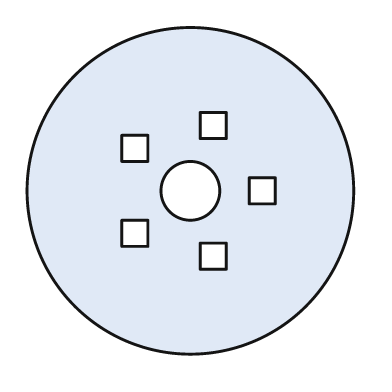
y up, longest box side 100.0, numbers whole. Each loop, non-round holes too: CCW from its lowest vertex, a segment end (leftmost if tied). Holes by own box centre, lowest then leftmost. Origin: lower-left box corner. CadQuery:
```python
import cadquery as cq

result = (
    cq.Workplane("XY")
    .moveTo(50.0, 50.0)
    .circle(50.0)
    .moveTo(53.0, 26.0)
    .lineTo(61.0, 26.0)
    .lineTo(61.0, 34.0)
    .lineTo(53.0, 34.0)
    .close()
    .moveTo(29.0, 33.0)
    .lineTo(37.0, 33.0)
    .lineTo(37.0, 41.0)
    .lineTo(29.0, 41.0)
    .close()
    .moveTo(50.0, 50.0)
    .circle(9.0)
    .moveTo(68.0, 46.0)
    .lineTo(76.0, 46.0)
    .lineTo(76.0, 54.0)
    .lineTo(68.0, 54.0)
    .close()
    .moveTo(29.0, 59.0)
    .lineTo(37.0, 59.0)
    .lineTo(37.0, 67.0)
    .lineTo(29.0, 67.0)
    .close()
    .moveTo(53.0, 66.0)
    .lineTo(61.0, 66.0)
    .lineTo(61.0, 74.0)
    .lineTo(53.0, 74.0)
    .close()
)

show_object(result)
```